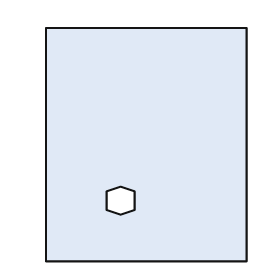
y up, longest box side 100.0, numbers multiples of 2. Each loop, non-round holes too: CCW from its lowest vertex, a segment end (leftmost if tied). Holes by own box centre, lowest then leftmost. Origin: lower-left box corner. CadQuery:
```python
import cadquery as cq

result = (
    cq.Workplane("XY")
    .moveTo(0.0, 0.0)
    .lineTo(86.0, 0.0)
    .lineTo(86.0, 100.0)
    .lineTo(0.0, 100.0)
    .close()
    .moveTo(32.0, 20.0)
    .lineTo(38.0, 22.0)
    .lineTo(38.0, 30.0)
    .lineTo(32.0, 32.0)
    .lineTo(26.0, 30.0)
    .lineTo(26.0, 22.0)
    .close()
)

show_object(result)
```